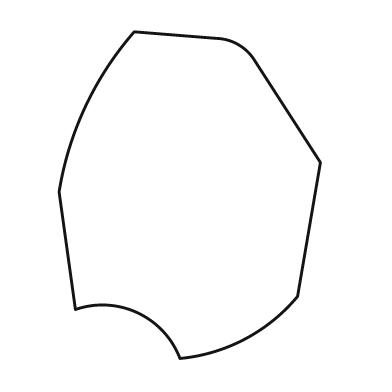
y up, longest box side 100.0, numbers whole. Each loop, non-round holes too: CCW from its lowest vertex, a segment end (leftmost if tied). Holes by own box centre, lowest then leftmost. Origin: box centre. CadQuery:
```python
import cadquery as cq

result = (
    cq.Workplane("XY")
    .moveTo(-3.0, -50.0)
    .threePointArc((17.0, -44.0), (33.0, -31.0))
    .lineTo(40.0, 10.0)
    .lineTo(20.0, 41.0)
    .threePointArc((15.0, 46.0), (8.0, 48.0))
    .lineTo(-17.0, 50.0)
    .threePointArc((-32.0, 27.0), (-40.0, 1.0))
    .lineTo(-35.0, -35.0)
    .threePointArc((-16.0, -36.0), (-3.0, -50.0))
    .close()
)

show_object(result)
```